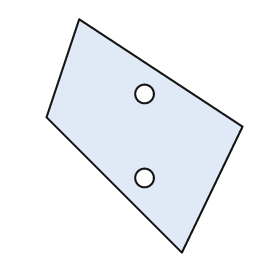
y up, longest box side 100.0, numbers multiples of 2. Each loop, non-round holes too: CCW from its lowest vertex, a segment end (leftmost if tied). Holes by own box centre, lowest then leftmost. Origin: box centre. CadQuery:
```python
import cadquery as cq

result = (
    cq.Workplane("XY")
    .moveTo(16.0, -50.0)
    .lineTo(42.0, 4.0)
    .lineTo(-28.0, 50.0)
    .lineTo(-42.0, 8.0)
    .close()
    .moveTo(0.0, -18.0)
    .circle(4.0)
    .moveTo(0.0, 18.0)
    .circle(4.0)
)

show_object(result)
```